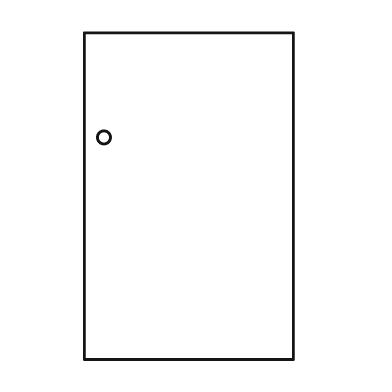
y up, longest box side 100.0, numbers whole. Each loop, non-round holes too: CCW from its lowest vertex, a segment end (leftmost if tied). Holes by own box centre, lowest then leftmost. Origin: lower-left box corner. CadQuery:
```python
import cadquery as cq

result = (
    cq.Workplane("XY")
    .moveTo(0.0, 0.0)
    .lineTo(64.0, 0.0)
    .lineTo(64.0, 100.0)
    .lineTo(0.0, 100.0)
    .close()
    .moveTo(6.0, 68.0)
    .circle(2.0)
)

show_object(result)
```